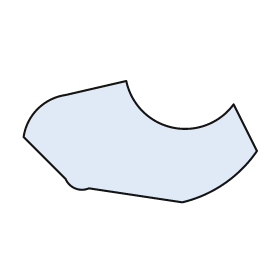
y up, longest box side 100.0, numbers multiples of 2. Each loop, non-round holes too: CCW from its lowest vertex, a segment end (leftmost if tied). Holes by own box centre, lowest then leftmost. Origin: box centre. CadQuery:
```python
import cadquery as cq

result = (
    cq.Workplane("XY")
    .moveTo(18.0, -26.0)
    .threePointArc((36.0, -18.0), (50.0, -4.0))
    .lineTo(40.0, 16.0)
    .threePointArc((14.0, 6.0), (-6.0, 26.0))
    .lineTo(-32.0, 20.0)
    .threePointArc((-44.0, 14.0), (-50.0, 2.0))
    .lineTo(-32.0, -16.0)
    .threePointArc((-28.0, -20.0), (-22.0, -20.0))
    .close()
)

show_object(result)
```